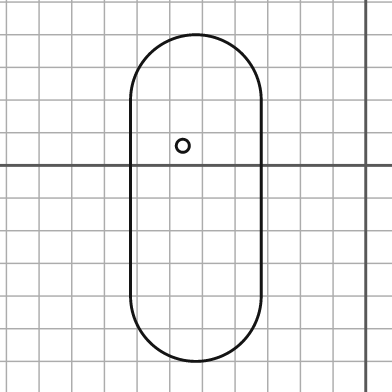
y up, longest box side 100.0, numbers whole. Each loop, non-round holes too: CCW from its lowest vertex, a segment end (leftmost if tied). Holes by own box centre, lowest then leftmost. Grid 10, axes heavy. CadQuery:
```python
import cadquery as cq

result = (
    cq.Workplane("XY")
    .moveTo(-72.0, -40.0)
    .threePointArc((-52.0, -60.0), (-32.0, -40.0))
    .lineTo(-32.0, 20.0)
    .threePointArc((-52.0, 40.0), (-72.0, 20.0))
    .close()
    .moveTo(-56.0, 6.0)
    .circle(2.0)
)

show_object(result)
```